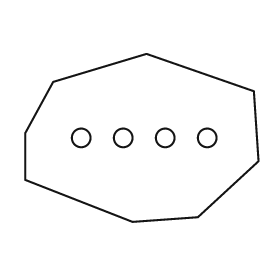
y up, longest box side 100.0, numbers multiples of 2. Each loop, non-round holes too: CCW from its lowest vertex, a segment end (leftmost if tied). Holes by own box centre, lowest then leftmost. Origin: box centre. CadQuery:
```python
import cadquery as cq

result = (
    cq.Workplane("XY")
    .moveTo(-4.0, -36.0)
    .lineTo(24.0, -34.0)
    .lineTo(50.0, -10.0)
    .lineTo(48.0, 20.0)
    .lineTo(2.0, 36.0)
    .lineTo(-38.0, 24.0)
    .lineTo(-50.0, 2.0)
    .lineTo(-50.0, -18.0)
    .close()
    .moveTo(-26.0, 0.0)
    .circle(4.0)
    .moveTo(-8.0, 0.0)
    .circle(4.0)
    .moveTo(10.0, 0.0)
    .circle(4.0)
    .moveTo(28.0, 0.0)
    .circle(4.0)
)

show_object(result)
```